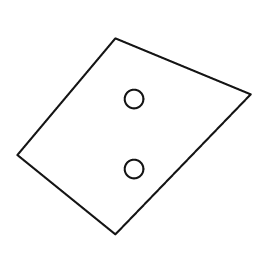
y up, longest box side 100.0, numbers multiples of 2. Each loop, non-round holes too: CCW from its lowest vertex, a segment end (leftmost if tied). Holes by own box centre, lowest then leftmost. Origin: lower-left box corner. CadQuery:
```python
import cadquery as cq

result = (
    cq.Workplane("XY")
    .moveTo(42.0, 0.0)
    .lineTo(100.0, 60.0)
    .lineTo(42.0, 84.0)
    .lineTo(0.0, 34.0)
    .close()
    .moveTo(50.0, 28.0)
    .circle(4.0)
    .moveTo(50.0, 58.0)
    .circle(4.0)
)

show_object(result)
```